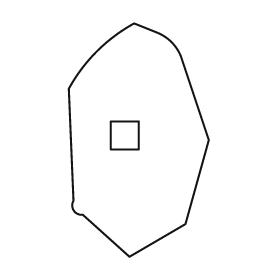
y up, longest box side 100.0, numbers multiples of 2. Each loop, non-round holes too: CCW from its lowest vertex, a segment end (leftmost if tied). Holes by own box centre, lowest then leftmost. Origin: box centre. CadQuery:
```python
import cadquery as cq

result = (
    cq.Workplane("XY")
    .moveTo(-4.0, -50.0)
    .lineTo(20.0, -36.0)
    .lineTo(30.0, 0.0)
    .lineTo(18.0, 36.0)
    .threePointArc((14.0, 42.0), (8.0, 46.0))
    .lineTo(-2.0, 50.0)
    .threePointArc((-18.0, 38.0), (-30.0, 22.0))
    .lineTo(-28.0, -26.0)
    .threePointArc((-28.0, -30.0), (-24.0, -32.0))
    .close()
    .moveTo(-12.0, -4.0)
    .lineTo(0.0, -4.0)
    .lineTo(0.0, 8.0)
    .lineTo(-12.0, 8.0)
    .close()
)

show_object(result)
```